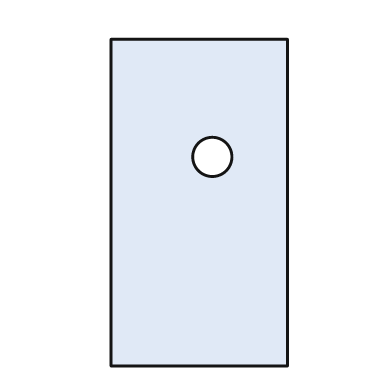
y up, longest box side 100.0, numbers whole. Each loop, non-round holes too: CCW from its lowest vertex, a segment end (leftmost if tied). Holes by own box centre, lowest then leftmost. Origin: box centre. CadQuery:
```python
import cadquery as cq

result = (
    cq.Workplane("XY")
    .moveTo(-27.0, -50.0)
    .lineTo(27.0, -50.0)
    .lineTo(27.0, 50.0)
    .lineTo(-27.0, 50.0)
    .close()
    .moveTo(4.0, 14.0)
    .circle(6.0)
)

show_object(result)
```